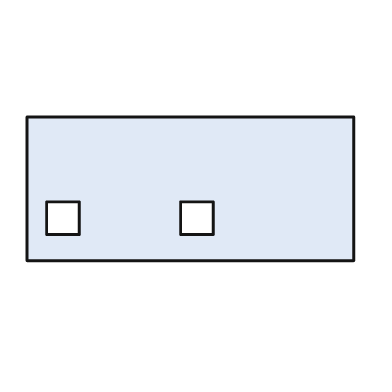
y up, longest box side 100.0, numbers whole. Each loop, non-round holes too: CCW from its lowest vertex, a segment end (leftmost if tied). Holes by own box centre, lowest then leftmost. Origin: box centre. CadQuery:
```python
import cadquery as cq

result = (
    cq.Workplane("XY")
    .moveTo(-50.0, -22.0)
    .lineTo(50.0, -22.0)
    .lineTo(50.0, 22.0)
    .lineTo(-50.0, 22.0)
    .close()
    .moveTo(-44.0, -14.0)
    .lineTo(-34.0, -14.0)
    .lineTo(-34.0, -4.0)
    .lineTo(-44.0, -4.0)
    .close()
    .moveTo(-3.0, -14.0)
    .lineTo(7.0, -14.0)
    .lineTo(7.0, -4.0)
    .lineTo(-3.0, -4.0)
    .close()
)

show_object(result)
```